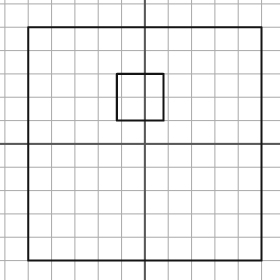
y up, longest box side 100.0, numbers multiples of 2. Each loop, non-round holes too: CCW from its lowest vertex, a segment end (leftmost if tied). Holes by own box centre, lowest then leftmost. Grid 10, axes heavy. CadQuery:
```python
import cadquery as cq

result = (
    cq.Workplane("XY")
    .moveTo(-50.0, -50.0)
    .lineTo(50.0, -50.0)
    .lineTo(50.0, 50.0)
    .lineTo(-50.0, 50.0)
    .close()
    .moveTo(-12.0, 10.0)
    .lineTo(8.0, 10.0)
    .lineTo(8.0, 30.0)
    .lineTo(-12.0, 30.0)
    .close()
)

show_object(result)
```